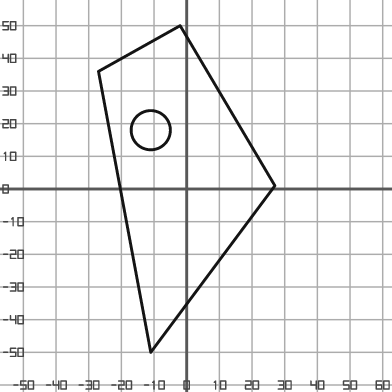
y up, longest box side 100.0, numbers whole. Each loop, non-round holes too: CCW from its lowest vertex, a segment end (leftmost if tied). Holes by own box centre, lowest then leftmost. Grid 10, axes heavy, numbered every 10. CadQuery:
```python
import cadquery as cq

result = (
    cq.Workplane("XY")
    .moveTo(-11.0, -50.0)
    .lineTo(27.0, 1.0)
    .lineTo(-2.0, 50.0)
    .lineTo(-27.0, 36.0)
    .close()
    .moveTo(-11.0, 18.0)
    .circle(6.0)
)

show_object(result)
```